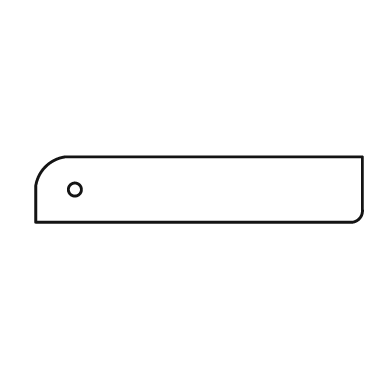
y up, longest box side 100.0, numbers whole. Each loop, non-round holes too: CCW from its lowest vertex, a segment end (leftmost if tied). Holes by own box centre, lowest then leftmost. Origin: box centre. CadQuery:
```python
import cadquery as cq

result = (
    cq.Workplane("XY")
    .moveTo(-50.0, -10.0)
    .lineTo(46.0, -10.0)
    .threePointArc((49.0, -9.0), (50.0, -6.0))
    .lineTo(50.0, 10.0)
    .lineTo(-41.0, 10.0)
    .threePointArc((-47.0, 7.0), (-50.0, 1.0))
    .close()
    .moveTo(-38.0, 0.0)
    .circle(2.0)
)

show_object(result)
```